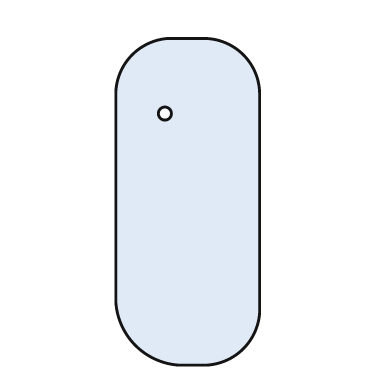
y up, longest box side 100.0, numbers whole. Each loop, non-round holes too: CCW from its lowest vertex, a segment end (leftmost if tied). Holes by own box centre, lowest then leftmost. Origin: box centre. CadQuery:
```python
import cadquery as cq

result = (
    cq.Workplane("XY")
    .moveTo(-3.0, -50.0)
    .lineTo(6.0, -50.0)
    .threePointArc((17.0, -45.0), (22.0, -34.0))
    .lineTo(22.0, 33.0)
    .threePointArc((17.0, 45.0), (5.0, 50.0))
    .lineTo(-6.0, 50.0)
    .threePointArc((-17.0, 45.0), (-22.0, 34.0))
    .lineTo(-22.0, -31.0)
    .threePointArc((-16.0, -44.0), (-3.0, -50.0))
    .close()
    .moveTo(-7.0, 27.0)
    .circle(2.0)
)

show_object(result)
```